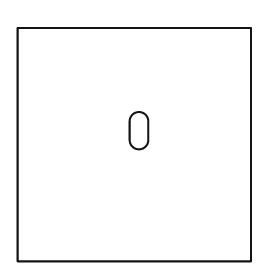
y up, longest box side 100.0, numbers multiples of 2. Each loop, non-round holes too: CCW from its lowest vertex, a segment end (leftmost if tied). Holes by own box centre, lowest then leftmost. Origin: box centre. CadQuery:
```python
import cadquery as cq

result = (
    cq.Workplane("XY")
    .moveTo(-50.0, -50.0)
    .lineTo(50.0, -50.0)
    .lineTo(50.0, 50.0)
    .lineTo(-50.0, 50.0)
    .close()
    .moveTo(-2.0, 2.0)
    .threePointArc((2.0, -2.0), (6.0, 2.0))
    .lineTo(6.0, 10.0)
    .threePointArc((2.0, 14.0), (-2.0, 10.0))
    .close()
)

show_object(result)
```